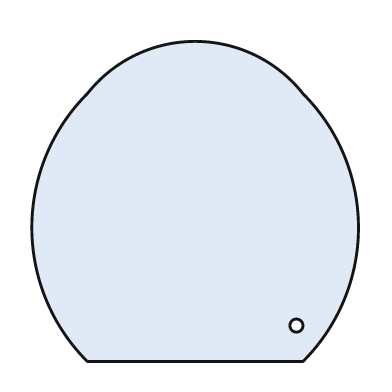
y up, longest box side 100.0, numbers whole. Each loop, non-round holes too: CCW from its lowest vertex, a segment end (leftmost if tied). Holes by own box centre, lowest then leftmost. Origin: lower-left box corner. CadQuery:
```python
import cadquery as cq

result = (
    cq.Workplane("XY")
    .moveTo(17.0, 0.0)
    .lineTo(83.0, 0.0)
    .threePointArc((100.0, 41.0), (83.0, 82.0))
    .threePointArc((50.0, 98.0), (17.0, 82.0))
    .threePointArc((0.0, 41.0), (17.0, 0.0))
    .close()
    .moveTo(81.0, 11.0)
    .circle(2.0)
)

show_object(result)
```